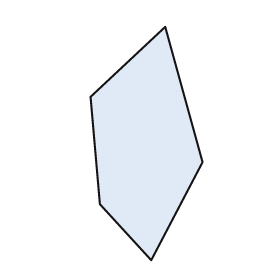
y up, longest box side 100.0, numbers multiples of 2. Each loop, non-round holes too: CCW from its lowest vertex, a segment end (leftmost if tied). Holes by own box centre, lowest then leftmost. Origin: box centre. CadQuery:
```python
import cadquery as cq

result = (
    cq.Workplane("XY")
    .moveTo(2.0, -50.0)
    .lineTo(24.0, -8.0)
    .lineTo(8.0, 50.0)
    .lineTo(-24.0, 20.0)
    .lineTo(-20.0, -26.0)
    .close()
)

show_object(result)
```